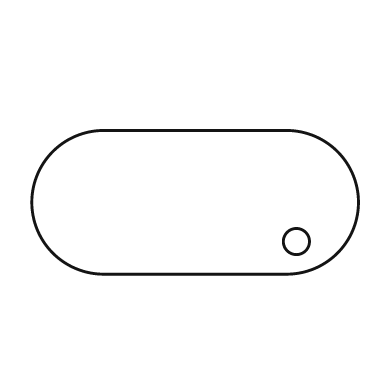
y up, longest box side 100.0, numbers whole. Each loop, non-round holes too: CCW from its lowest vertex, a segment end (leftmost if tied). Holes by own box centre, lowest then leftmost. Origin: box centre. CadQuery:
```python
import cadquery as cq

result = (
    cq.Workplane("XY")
    .moveTo(-28.0, -22.0)
    .lineTo(28.0, -22.0)
    .threePointArc((50.0, 0.0), (28.0, 22.0))
    .lineTo(-28.0, 22.0)
    .threePointArc((-50.0, 0.0), (-28.0, -22.0))
    .close()
    .moveTo(31.0, -12.0)
    .circle(4.0)
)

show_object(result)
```